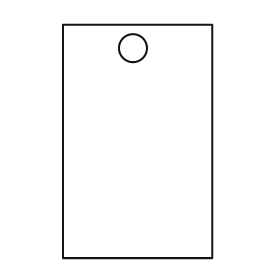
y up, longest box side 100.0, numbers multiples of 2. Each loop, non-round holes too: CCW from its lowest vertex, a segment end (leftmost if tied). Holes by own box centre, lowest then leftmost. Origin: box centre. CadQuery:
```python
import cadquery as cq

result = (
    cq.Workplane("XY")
    .moveTo(-32.0, -50.0)
    .lineTo(32.0, -50.0)
    .lineTo(32.0, 50.0)
    .lineTo(-32.0, 50.0)
    .close()
    .moveTo(-2.0, 40.0)
    .circle(6.0)
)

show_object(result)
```